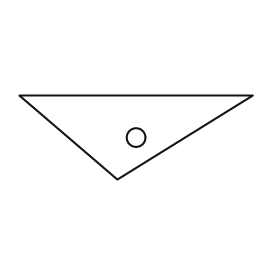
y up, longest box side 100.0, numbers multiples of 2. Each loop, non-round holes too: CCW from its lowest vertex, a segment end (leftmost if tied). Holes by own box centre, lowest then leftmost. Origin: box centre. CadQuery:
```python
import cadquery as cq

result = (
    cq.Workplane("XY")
    .moveTo(-8.0, -18.0)
    .lineTo(50.0, 18.0)
    .lineTo(-50.0, 18.0)
    .close()
    .moveTo(0.0, 0.0)
    .circle(4.0)
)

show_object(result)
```